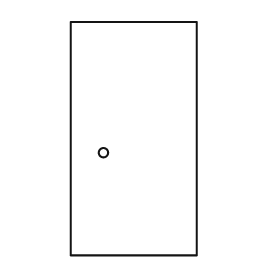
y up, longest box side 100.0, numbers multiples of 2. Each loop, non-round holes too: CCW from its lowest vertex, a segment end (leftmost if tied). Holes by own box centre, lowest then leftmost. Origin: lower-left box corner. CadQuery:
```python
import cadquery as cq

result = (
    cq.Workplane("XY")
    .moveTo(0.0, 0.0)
    .lineTo(54.0, 0.0)
    .lineTo(54.0, 100.0)
    .lineTo(0.0, 100.0)
    .close()
    .moveTo(14.0, 44.0)
    .circle(2.0)
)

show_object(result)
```